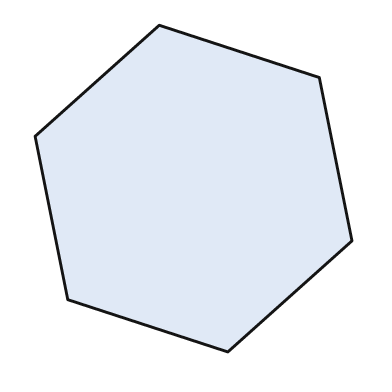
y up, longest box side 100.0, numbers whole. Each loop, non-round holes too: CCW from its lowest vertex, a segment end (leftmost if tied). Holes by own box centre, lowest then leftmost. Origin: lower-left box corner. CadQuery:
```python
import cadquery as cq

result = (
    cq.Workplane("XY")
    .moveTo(59.0, 0.0)
    .lineTo(97.0, 34.0)
    .lineTo(87.0, 84.0)
    .lineTo(38.0, 100.0)
    .lineTo(0.0, 66.0)
    .lineTo(10.0, 16.0)
    .close()
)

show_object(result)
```